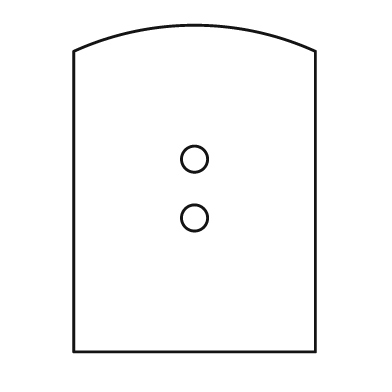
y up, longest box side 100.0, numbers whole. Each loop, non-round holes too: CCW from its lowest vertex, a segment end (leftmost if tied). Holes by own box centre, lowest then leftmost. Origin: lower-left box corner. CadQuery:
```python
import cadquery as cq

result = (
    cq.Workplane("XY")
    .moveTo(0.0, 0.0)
    .lineTo(74.0, 0.0)
    .lineTo(74.0, 92.0)
    .threePointArc((37.0, 100.0), (0.0, 92.0))
    .close()
    .moveTo(37.0, 41.0)
    .circle(4.0)
    .moveTo(37.0, 59.0)
    .circle(4.0)
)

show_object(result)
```